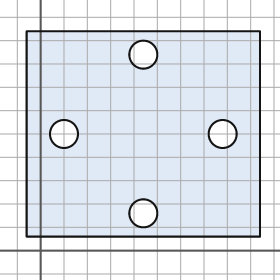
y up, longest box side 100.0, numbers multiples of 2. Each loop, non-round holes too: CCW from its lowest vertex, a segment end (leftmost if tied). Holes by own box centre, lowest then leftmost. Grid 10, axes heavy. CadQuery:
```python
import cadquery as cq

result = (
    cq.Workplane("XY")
    .moveTo(-6.0, 6.0)
    .lineTo(94.0, 6.0)
    .lineTo(94.0, 94.0)
    .lineTo(-6.0, 94.0)
    .close()
    .moveTo(44.0, 16.0)
    .circle(6.0)
    .moveTo(10.0, 50.0)
    .circle(6.0)
    .moveTo(78.0, 50.0)
    .circle(6.0)
    .moveTo(44.0, 84.0)
    .circle(6.0)
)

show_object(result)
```